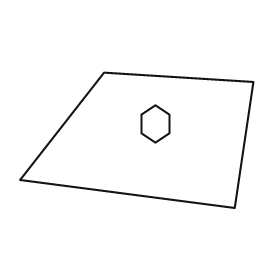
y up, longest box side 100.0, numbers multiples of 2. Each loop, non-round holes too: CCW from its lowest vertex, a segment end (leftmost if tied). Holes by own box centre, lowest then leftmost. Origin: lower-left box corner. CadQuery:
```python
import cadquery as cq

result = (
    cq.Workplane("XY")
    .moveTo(92.0, 0.0)
    .lineTo(100.0, 54.0)
    .lineTo(36.0, 58.0)
    .lineTo(0.0, 12.0)
    .close()
    .moveTo(58.0, 28.0)
    .lineTo(64.0, 32.0)
    .lineTo(64.0, 40.0)
    .lineTo(58.0, 44.0)
    .lineTo(52.0, 40.0)
    .lineTo(52.0, 32.0)
    .close()
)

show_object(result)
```